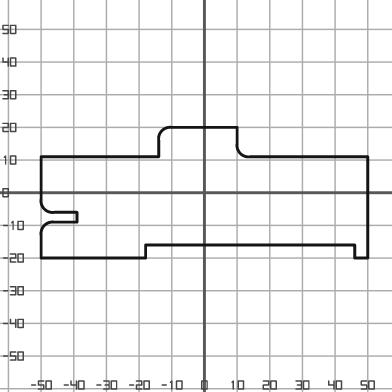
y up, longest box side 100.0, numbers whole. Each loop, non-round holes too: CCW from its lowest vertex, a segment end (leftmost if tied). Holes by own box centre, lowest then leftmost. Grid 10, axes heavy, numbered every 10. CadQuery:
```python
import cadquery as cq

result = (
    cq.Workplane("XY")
    .moveTo(-50.0, -20.0)
    .lineTo(-18.0, -20.0)
    .lineTo(-18.0, -16.0)
    .lineTo(46.0, -16.0)
    .lineTo(46.0, -20.0)
    .lineTo(50.0, -20.0)
    .lineTo(50.0, 11.0)
    .lineTo(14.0, 11.0)
    .threePointArc((11.0, 12.0), (10.0, 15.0))
    .lineTo(10.0, 20.0)
    .lineTo(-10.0, 20.0)
    .threePointArc((-13.0, 19.0), (-14.0, 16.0))
    .lineTo(-14.0, 11.0)
    .lineTo(-50.0, 11.0)
    .lineTo(-50.0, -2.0)
    .threePointArc((-49.0, -5.0), (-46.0, -6.0))
    .lineTo(-39.0, -6.0)
    .lineTo(-39.0, -9.0)
    .lineTo(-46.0, -9.0)
    .threePointArc((-49.0, -10.0), (-50.0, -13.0))
    .close()
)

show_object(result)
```